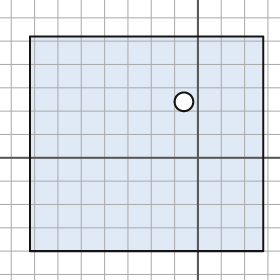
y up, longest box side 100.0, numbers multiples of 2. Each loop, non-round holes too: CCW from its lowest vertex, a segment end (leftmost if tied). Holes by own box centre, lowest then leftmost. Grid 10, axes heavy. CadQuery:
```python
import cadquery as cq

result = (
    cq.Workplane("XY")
    .moveTo(-72.0, -40.0)
    .lineTo(28.0, -40.0)
    .lineTo(28.0, 52.0)
    .lineTo(-72.0, 52.0)
    .close()
    .moveTo(-6.0, 24.0)
    .circle(4.0)
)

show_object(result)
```